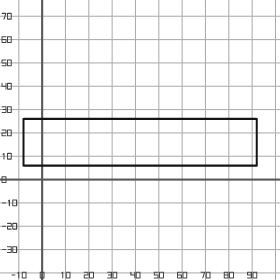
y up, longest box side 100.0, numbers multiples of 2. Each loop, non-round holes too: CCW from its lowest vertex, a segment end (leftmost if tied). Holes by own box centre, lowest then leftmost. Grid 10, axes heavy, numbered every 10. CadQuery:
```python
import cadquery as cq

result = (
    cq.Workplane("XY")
    .moveTo(-8.0, 6.0)
    .lineTo(92.0, 6.0)
    .lineTo(92.0, 26.0)
    .lineTo(-8.0, 26.0)
    .close()
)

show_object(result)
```